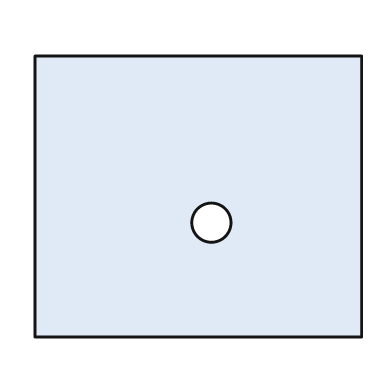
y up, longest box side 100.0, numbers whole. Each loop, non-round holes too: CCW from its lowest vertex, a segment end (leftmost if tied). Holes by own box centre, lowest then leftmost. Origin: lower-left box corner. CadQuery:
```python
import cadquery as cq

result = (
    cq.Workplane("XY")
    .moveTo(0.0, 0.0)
    .lineTo(100.0, 0.0)
    .lineTo(100.0, 86.0)
    .lineTo(0.0, 86.0)
    .close()
    .moveTo(54.0, 35.0)
    .circle(6.0)
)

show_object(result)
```